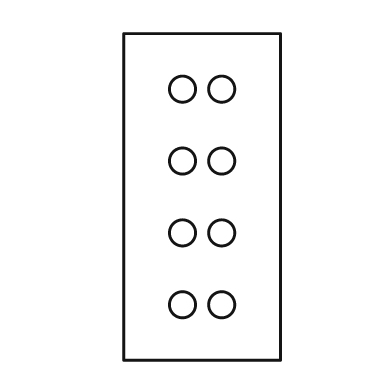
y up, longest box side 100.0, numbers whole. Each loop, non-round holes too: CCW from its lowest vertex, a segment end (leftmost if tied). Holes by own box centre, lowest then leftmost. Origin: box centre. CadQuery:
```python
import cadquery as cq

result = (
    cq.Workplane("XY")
    .moveTo(-24.0, -50.0)
    .lineTo(24.0, -50.0)
    .lineTo(24.0, 50.0)
    .lineTo(-24.0, 50.0)
    .close()
    .moveTo(-6.0, -33.0)
    .circle(4.0)
    .moveTo(6.0, -33.0)
    .circle(4.0)
    .moveTo(-6.0, -11.0)
    .circle(4.0)
    .moveTo(6.0, -11.0)
    .circle(4.0)
    .moveTo(-6.0, 11.0)
    .circle(4.0)
    .moveTo(6.0, 11.0)
    .circle(4.0)
    .moveTo(-6.0, 33.0)
    .circle(4.0)
    .moveTo(6.0, 33.0)
    .circle(4.0)
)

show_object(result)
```